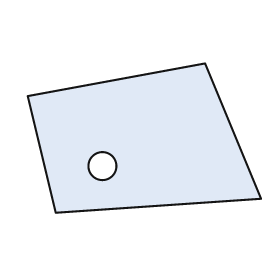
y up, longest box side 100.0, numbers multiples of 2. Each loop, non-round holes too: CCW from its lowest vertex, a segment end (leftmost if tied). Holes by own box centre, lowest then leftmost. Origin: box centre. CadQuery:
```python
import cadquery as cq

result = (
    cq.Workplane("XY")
    .moveTo(-38.0, -32.0)
    .lineTo(50.0, -26.0)
    .lineTo(26.0, 32.0)
    .lineTo(-50.0, 18.0)
    .close()
    .moveTo(-18.0, -12.0)
    .circle(6.0)
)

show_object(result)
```